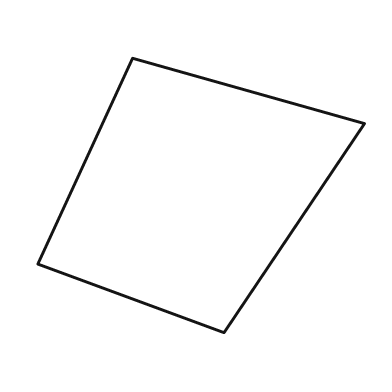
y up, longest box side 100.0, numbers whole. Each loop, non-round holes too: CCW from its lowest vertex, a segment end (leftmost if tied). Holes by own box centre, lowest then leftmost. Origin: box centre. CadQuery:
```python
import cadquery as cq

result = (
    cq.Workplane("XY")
    .moveTo(7.0, -42.0)
    .lineTo(50.0, 22.0)
    .lineTo(-21.0, 42.0)
    .lineTo(-50.0, -21.0)
    .close()
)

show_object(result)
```